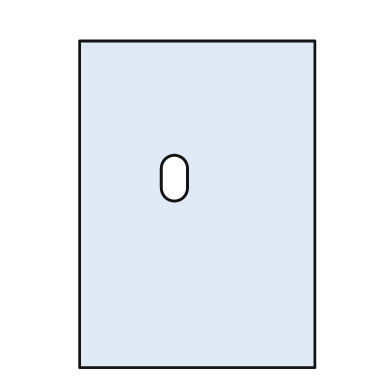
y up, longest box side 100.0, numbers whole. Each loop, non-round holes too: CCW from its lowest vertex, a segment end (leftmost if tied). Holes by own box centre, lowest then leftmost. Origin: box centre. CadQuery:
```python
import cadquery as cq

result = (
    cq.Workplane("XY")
    .moveTo(-36.0, -50.0)
    .lineTo(36.0, -50.0)
    .lineTo(36.0, 50.0)
    .lineTo(-36.0, 50.0)
    .close()
    .moveTo(-11.0, 5.0)
    .threePointArc((-7.0, 1.0), (-3.0, 5.0))
    .lineTo(-3.0, 11.0)
    .threePointArc((-7.0, 15.0), (-11.0, 11.0))
    .close()
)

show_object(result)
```